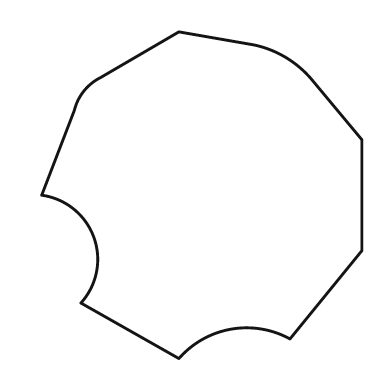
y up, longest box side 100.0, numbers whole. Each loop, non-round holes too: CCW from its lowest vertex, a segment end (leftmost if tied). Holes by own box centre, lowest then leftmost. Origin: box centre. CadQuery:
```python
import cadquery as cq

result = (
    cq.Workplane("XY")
    .moveTo(-7.0, -50.0)
    .threePointArc((9.0, -41.0), (27.0, -44.0))
    .lineTo(49.0, -17.0)
    .lineTo(49.0, 17.0)
    .lineTo(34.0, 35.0)
    .threePointArc((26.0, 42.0), (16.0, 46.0))
    .lineTo(-7.0, 50.0)
    .lineTo(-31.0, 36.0)
    .threePointArc((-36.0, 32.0), (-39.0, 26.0))
    .lineTo(-49.0, 0.0)
    .threePointArc((-33.0, -13.0), (-37.0, -33.0))
    .close()
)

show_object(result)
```